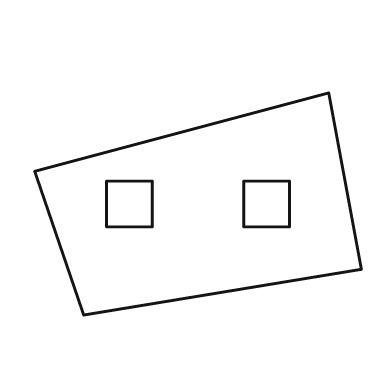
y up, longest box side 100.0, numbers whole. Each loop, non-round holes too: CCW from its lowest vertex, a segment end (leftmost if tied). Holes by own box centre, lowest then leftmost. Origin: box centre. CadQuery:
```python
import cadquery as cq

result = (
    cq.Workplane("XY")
    .moveTo(-35.0, -34.0)
    .lineTo(50.0, -20.0)
    .lineTo(40.0, 34.0)
    .lineTo(-50.0, 10.0)
    .close()
    .moveTo(-28.0, -7.0)
    .lineTo(-14.0, -7.0)
    .lineTo(-14.0, 7.0)
    .lineTo(-28.0, 7.0)
    .close()
    .moveTo(14.0, -7.0)
    .lineTo(28.0, -7.0)
    .lineTo(28.0, 7.0)
    .lineTo(14.0, 7.0)
    .close()
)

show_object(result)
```